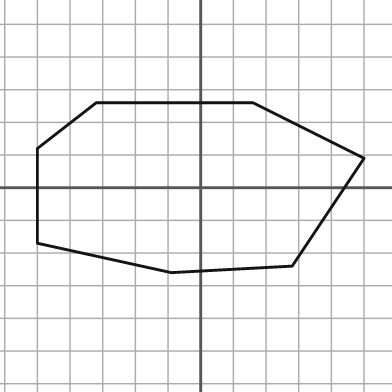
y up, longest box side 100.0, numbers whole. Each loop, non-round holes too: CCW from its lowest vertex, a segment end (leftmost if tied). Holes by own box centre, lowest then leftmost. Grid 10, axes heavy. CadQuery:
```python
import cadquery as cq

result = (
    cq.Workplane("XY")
    .moveTo(-9.0, -26.0)
    .lineTo(28.0, -24.0)
    .lineTo(50.0, 9.0)
    .lineTo(16.0, 26.0)
    .lineTo(-32.0, 26.0)
    .lineTo(-50.0, 12.0)
    .lineTo(-50.0, -17.0)
    .close()
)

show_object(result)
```